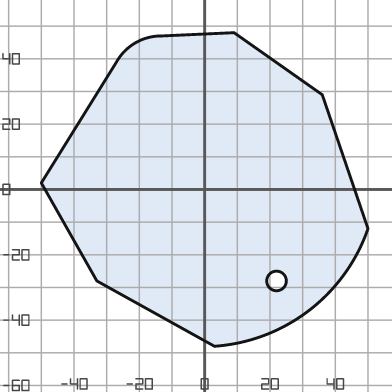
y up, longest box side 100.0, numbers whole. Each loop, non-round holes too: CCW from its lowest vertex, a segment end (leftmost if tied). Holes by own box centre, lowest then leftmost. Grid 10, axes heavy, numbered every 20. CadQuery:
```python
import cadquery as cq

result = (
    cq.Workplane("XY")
    .moveTo(3.0, -48.0)
    .threePointArc((32.0, -37.0), (50.0, -12.0))
    .lineTo(36.0, 29.0)
    .lineTo(9.0, 48.0)
    .lineTo(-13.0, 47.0)
    .threePointArc((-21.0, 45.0), (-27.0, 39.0))
    .lineTo(-50.0, 2.0)
    .lineTo(-33.0, -28.0)
    .close()
    .moveTo(22.0, -28.0)
    .circle(3.0)
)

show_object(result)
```